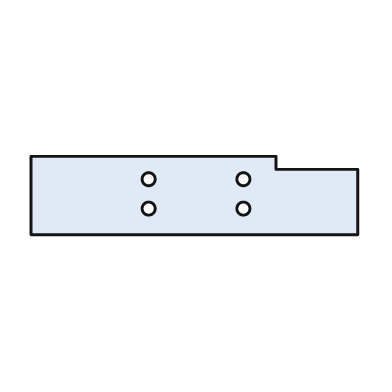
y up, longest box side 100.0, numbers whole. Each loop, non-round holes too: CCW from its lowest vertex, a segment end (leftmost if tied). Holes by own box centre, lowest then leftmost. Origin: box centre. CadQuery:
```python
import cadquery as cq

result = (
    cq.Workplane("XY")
    .moveTo(-50.0, -12.0)
    .lineTo(50.0, -12.0)
    .lineTo(50.0, 8.0)
    .lineTo(25.0, 8.0)
    .lineTo(25.0, 12.0)
    .lineTo(-50.0, 12.0)
    .close()
    .moveTo(-14.0, -4.0)
    .circle(2.0)
    .moveTo(15.0, -4.0)
    .circle(2.0)
    .moveTo(-14.0, 5.0)
    .circle(2.0)
    .moveTo(15.0, 5.0)
    .circle(2.0)
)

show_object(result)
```